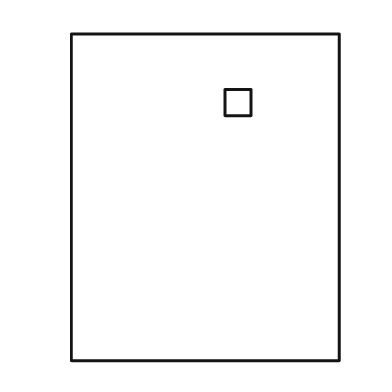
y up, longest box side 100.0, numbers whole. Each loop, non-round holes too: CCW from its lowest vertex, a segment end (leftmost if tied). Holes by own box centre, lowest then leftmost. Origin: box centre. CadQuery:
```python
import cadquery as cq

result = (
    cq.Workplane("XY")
    .moveTo(-41.0, -50.0)
    .lineTo(41.0, -50.0)
    .lineTo(41.0, 50.0)
    .lineTo(-41.0, 50.0)
    .close()
    .moveTo(6.0, 25.0)
    .lineTo(14.0, 25.0)
    .lineTo(14.0, 33.0)
    .lineTo(6.0, 33.0)
    .close()
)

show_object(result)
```